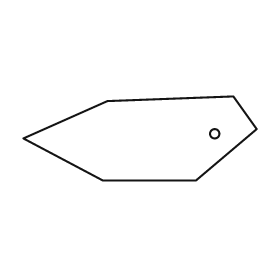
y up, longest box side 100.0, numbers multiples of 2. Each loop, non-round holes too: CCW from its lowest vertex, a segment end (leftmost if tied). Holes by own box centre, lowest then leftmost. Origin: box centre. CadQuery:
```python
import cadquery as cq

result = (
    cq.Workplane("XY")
    .moveTo(-16.0, -18.0)
    .lineTo(24.0, -18.0)
    .lineTo(50.0, 4.0)
    .lineTo(40.0, 18.0)
    .lineTo(-14.0, 16.0)
    .lineTo(-50.0, 0.0)
    .close()
    .moveTo(32.0, 2.0)
    .circle(2.0)
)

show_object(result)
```